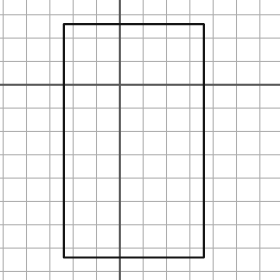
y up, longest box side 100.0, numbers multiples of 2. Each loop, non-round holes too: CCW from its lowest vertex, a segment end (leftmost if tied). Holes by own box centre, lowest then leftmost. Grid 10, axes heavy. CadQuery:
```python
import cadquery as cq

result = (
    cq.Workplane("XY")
    .moveTo(-24.0, -74.0)
    .lineTo(36.0, -74.0)
    .lineTo(36.0, 26.0)
    .lineTo(-24.0, 26.0)
    .close()
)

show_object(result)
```